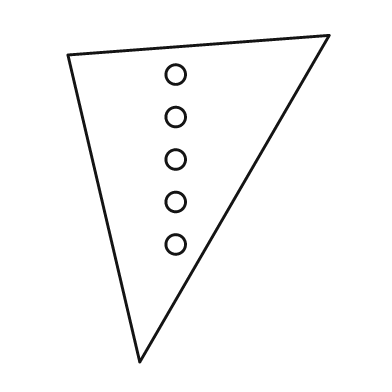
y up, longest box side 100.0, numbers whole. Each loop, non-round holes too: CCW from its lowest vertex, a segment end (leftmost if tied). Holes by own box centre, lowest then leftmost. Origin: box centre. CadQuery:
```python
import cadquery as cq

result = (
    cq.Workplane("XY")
    .moveTo(-18.0, -50.0)
    .lineTo(40.0, 50.0)
    .lineTo(-40.0, 44.0)
    .close()
    .moveTo(-7.0, -14.0)
    .circle(3.0)
    .moveTo(-7.0, -1.0)
    .circle(3.0)
    .moveTo(-7.0, 12.0)
    .circle(3.0)
    .moveTo(-7.0, 25.0)
    .circle(3.0)
    .moveTo(-7.0, 38.0)
    .circle(3.0)
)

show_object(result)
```